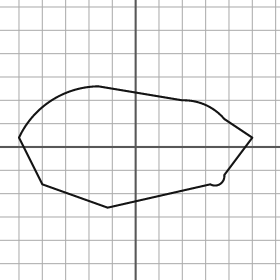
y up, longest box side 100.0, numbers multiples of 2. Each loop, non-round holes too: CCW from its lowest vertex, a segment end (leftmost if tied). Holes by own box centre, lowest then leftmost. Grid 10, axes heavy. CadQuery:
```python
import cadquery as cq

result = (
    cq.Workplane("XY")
    .moveTo(-12.0, -26.0)
    .lineTo(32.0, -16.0)
    .threePointArc((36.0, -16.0), (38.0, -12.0))
    .lineTo(50.0, 4.0)
    .lineTo(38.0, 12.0)
    .threePointArc((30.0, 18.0), (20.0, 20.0))
    .lineTo(-16.0, 26.0)
    .threePointArc((-36.0, 20.0), (-50.0, 4.0))
    .lineTo(-40.0, -16.0)
    .close()
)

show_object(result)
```